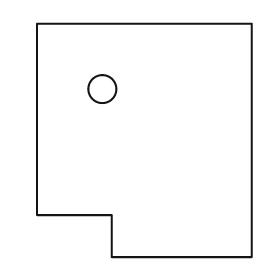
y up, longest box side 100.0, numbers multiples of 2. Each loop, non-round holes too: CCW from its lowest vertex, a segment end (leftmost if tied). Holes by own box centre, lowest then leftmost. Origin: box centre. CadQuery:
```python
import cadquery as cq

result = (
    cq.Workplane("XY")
    .moveTo(-14.0, -50.0)
    .lineTo(46.0, -50.0)
    .lineTo(46.0, 50.0)
    .lineTo(-46.0, 50.0)
    .lineTo(-46.0, -32.0)
    .lineTo(-14.0, -32.0)
    .close()
    .moveTo(-18.0, 22.0)
    .circle(6.0)
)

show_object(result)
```